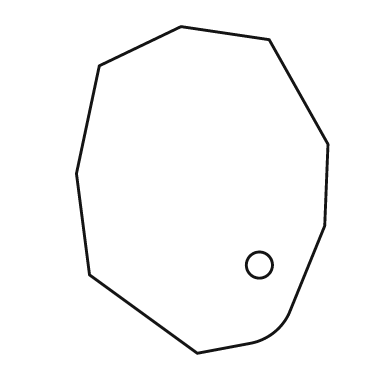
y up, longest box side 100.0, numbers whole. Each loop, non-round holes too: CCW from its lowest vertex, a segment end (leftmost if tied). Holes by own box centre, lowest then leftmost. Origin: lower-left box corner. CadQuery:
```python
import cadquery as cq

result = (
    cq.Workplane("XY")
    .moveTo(37.0, 0.0)
    .lineTo(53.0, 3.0)
    .threePointArc((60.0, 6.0), (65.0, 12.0))
    .lineTo(76.0, 39.0)
    .lineTo(77.0, 64.0)
    .lineTo(59.0, 96.0)
    .lineTo(32.0, 100.0)
    .lineTo(7.0, 88.0)
    .lineTo(0.0, 55.0)
    .lineTo(4.0, 24.0)
    .close()
    .moveTo(56.0, 27.0)
    .circle(4.0)
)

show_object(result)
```